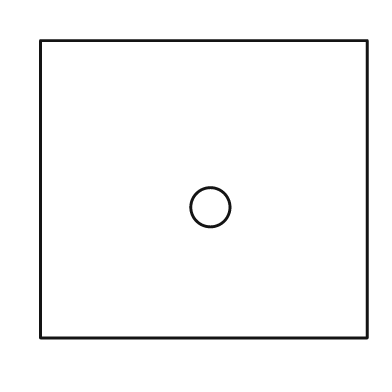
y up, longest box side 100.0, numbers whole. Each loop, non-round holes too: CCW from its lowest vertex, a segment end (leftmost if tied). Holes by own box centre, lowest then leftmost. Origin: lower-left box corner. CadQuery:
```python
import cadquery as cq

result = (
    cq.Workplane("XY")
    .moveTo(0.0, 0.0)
    .lineTo(100.0, 0.0)
    .lineTo(100.0, 91.0)
    .lineTo(0.0, 91.0)
    .close()
    .moveTo(52.0, 40.0)
    .circle(6.0)
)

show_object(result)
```